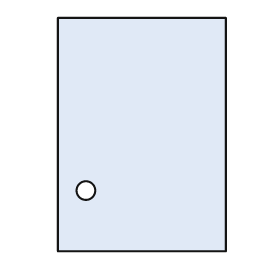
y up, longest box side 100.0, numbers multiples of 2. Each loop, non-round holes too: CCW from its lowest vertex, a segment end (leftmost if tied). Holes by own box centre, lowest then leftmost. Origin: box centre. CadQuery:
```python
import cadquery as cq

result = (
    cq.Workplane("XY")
    .moveTo(-36.0, -50.0)
    .lineTo(36.0, -50.0)
    .lineTo(36.0, 50.0)
    .lineTo(-36.0, 50.0)
    .close()
    .moveTo(-24.0, -24.0)
    .circle(4.0)
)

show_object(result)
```